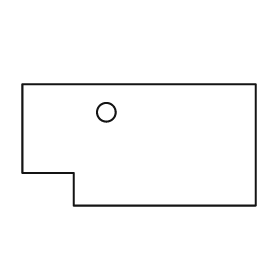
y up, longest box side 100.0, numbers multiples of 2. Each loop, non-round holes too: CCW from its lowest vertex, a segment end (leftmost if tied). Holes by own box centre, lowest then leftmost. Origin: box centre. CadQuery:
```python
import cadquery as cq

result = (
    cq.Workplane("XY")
    .moveTo(-28.0, -26.0)
    .lineTo(50.0, -26.0)
    .lineTo(50.0, 26.0)
    .lineTo(-50.0, 26.0)
    .lineTo(-50.0, -12.0)
    .lineTo(-28.0, -12.0)
    .close()
    .moveTo(-14.0, 14.0)
    .circle(4.0)
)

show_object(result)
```